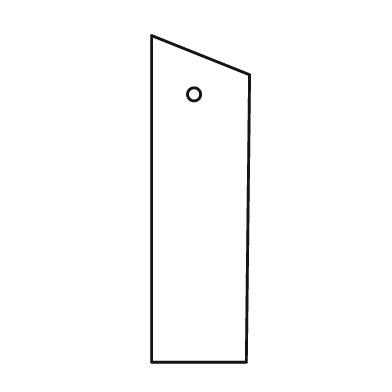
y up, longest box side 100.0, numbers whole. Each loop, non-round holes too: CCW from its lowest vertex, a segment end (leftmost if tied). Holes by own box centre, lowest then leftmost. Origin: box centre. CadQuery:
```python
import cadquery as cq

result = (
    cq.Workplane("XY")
    .moveTo(-15.0, -50.0)
    .lineTo(14.0, -50.0)
    .lineTo(15.0, 38.0)
    .lineTo(-15.0, 50.0)
    .close()
    .moveTo(-2.0, 32.0)
    .circle(2.0)
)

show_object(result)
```